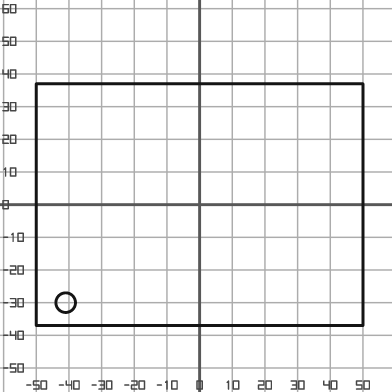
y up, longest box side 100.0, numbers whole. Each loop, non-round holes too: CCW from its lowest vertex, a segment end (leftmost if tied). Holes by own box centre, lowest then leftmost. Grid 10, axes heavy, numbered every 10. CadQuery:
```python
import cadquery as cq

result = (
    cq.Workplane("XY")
    .moveTo(-50.0, -37.0)
    .lineTo(50.0, -37.0)
    .lineTo(50.0, 37.0)
    .lineTo(-50.0, 37.0)
    .close()
    .moveTo(-41.0, -30.0)
    .circle(3.0)
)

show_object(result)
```